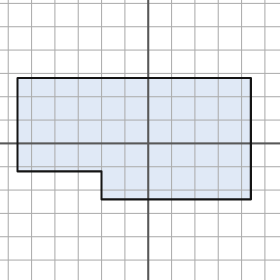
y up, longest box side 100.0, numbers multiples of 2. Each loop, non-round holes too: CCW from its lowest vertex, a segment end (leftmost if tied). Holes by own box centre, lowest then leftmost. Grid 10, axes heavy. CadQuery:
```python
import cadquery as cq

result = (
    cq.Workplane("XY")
    .moveTo(-20.0, -24.0)
    .lineTo(44.0, -24.0)
    .lineTo(44.0, 28.0)
    .lineTo(-56.0, 28.0)
    .lineTo(-56.0, -12.0)
    .lineTo(-20.0, -12.0)
    .close()
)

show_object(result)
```